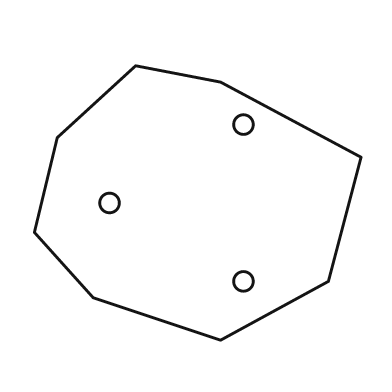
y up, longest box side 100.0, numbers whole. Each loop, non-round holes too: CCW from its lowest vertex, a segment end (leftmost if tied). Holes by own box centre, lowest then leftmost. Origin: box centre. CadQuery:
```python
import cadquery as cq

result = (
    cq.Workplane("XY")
    .moveTo(7.0, -42.0)
    .lineTo(40.0, -24.0)
    .lineTo(50.0, 14.0)
    .lineTo(7.0, 37.0)
    .lineTo(-19.0, 42.0)
    .lineTo(-43.0, 20.0)
    .lineTo(-50.0, -9.0)
    .lineTo(-32.0, -29.0)
    .close()
    .moveTo(14.0, -24.0)
    .circle(3.0)
    .moveTo(-27.0, 0.0)
    .circle(3.0)
    .moveTo(14.0, 24.0)
    .circle(3.0)
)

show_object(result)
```